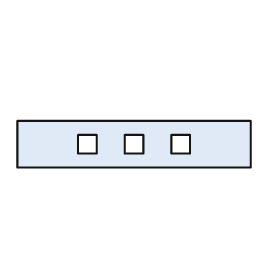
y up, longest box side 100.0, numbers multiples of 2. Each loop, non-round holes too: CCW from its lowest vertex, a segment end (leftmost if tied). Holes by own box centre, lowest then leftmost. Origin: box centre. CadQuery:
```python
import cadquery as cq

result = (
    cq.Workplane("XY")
    .moveTo(-50.0, -10.0)
    .lineTo(50.0, -10.0)
    .lineTo(50.0, 10.0)
    .lineTo(-50.0, 10.0)
    .close()
    .moveTo(-24.0, -4.0)
    .lineTo(-16.0, -4.0)
    .lineTo(-16.0, 4.0)
    .lineTo(-24.0, 4.0)
    .close()
    .moveTo(-4.0, -4.0)
    .lineTo(4.0, -4.0)
    .lineTo(4.0, 4.0)
    .lineTo(-4.0, 4.0)
    .close()
    .moveTo(16.0, -4.0)
    .lineTo(24.0, -4.0)
    .lineTo(24.0, 4.0)
    .lineTo(16.0, 4.0)
    .close()
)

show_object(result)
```